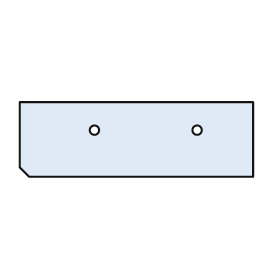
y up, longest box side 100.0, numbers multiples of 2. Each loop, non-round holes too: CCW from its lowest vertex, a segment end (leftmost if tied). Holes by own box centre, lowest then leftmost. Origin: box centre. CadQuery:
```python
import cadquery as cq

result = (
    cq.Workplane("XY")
    .moveTo(-46.0, -16.0)
    .lineTo(50.0, -16.0)
    .lineTo(50.0, 16.0)
    .lineTo(-50.0, 16.0)
    .lineTo(-50.0, -12.0)
    .close()
    .moveTo(-18.0, 4.0)
    .circle(2.0)
    .moveTo(26.0, 4.0)
    .circle(2.0)
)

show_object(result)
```